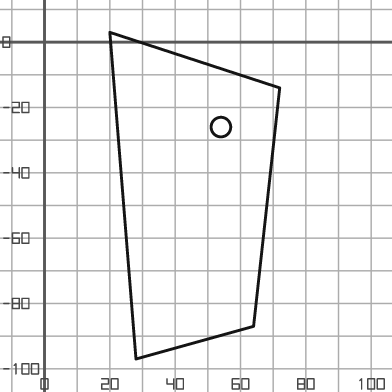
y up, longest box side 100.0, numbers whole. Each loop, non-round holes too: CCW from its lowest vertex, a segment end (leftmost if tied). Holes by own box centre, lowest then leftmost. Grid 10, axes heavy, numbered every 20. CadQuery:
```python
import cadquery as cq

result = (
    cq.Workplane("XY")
    .moveTo(28.0, -97.0)
    .lineTo(64.0, -87.0)
    .lineTo(72.0, -14.0)
    .lineTo(20.0, 3.0)
    .close()
    .moveTo(54.0, -26.0)
    .circle(3.0)
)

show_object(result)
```